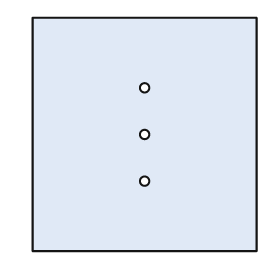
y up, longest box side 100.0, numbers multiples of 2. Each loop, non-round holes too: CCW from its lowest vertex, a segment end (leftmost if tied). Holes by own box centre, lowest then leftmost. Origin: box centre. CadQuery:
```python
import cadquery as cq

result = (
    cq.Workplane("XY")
    .moveTo(-48.0, -50.0)
    .lineTo(48.0, -50.0)
    .lineTo(48.0, 50.0)
    .lineTo(-48.0, 50.0)
    .close()
    .moveTo(0.0, -20.0)
    .circle(2.0)
    .moveTo(0.0, 0.0)
    .circle(2.0)
    .moveTo(0.0, 20.0)
    .circle(2.0)
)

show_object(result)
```